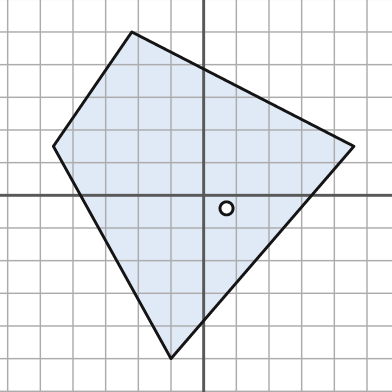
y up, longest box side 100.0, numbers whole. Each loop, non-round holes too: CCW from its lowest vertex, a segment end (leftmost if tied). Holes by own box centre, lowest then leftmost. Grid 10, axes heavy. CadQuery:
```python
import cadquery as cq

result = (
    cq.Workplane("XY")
    .moveTo(-10.0, -50.0)
    .lineTo(46.0, 15.0)
    .lineTo(-22.0, 50.0)
    .lineTo(-46.0, 15.0)
    .close()
    .moveTo(7.0, -4.0)
    .circle(2.0)
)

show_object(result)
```